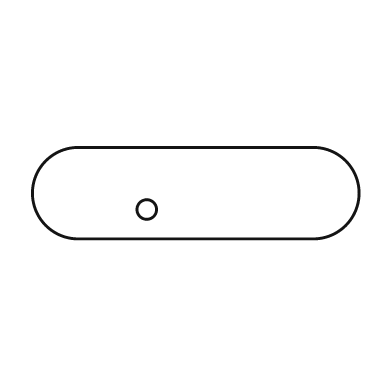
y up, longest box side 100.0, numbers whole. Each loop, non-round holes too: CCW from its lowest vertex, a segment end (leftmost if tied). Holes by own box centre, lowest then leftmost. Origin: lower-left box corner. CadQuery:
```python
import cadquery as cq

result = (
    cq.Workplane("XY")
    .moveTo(14.0, 0.0)
    .lineTo(86.0, 0.0)
    .threePointArc((100.0, 14.0), (86.0, 28.0))
    .lineTo(14.0, 28.0)
    .threePointArc((0.0, 14.0), (14.0, 0.0))
    .close()
    .moveTo(35.0, 9.0)
    .circle(3.0)
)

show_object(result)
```